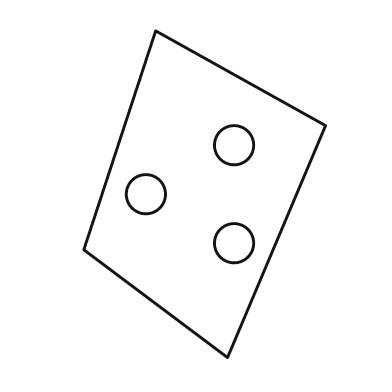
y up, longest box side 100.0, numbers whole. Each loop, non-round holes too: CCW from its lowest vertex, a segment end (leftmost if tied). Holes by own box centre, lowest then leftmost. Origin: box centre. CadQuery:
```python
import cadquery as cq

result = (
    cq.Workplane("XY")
    .moveTo(7.0, -50.0)
    .lineTo(37.0, 21.0)
    .lineTo(-15.0, 50.0)
    .lineTo(-37.0, -17.0)
    .close()
    .moveTo(9.0, -15.0)
    .circle(6.0)
    .moveTo(-18.0, 0.0)
    .circle(6.0)
    .moveTo(9.0, 15.0)
    .circle(6.0)
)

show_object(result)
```